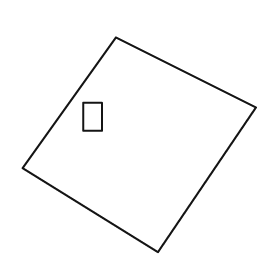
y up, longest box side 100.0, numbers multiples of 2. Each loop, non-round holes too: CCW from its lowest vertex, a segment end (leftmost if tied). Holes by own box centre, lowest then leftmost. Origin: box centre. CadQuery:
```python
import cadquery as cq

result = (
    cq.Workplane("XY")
    .moveTo(8.0, -46.0)
    .lineTo(50.0, 16.0)
    .lineTo(-10.0, 46.0)
    .lineTo(-50.0, -10.0)
    .close()
    .moveTo(-24.0, 6.0)
    .lineTo(-16.0, 6.0)
    .lineTo(-16.0, 18.0)
    .lineTo(-24.0, 18.0)
    .close()
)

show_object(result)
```